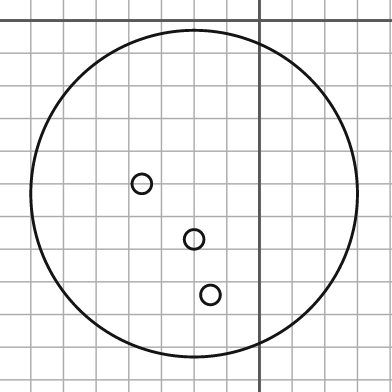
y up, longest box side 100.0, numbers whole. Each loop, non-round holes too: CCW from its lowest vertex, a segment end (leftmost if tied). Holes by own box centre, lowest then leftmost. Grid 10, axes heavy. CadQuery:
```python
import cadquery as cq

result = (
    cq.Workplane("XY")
    .moveTo(-20.0, -53.0)
    .circle(50.0)
    .moveTo(-15.0, -84.0)
    .circle(3.0)
    .moveTo(-20.0, -67.0)
    .circle(3.0)
    .moveTo(-36.0, -50.0)
    .circle(3.0)
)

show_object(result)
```